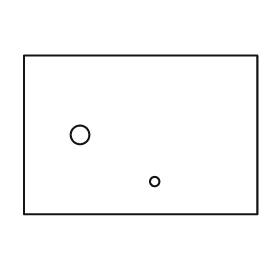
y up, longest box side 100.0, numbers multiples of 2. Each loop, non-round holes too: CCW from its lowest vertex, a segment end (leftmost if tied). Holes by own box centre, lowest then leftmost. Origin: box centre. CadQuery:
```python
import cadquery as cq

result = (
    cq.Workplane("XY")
    .moveTo(-50.0, -34.0)
    .lineTo(50.0, -34.0)
    .lineTo(50.0, 34.0)
    .lineTo(-50.0, 34.0)
    .close()
    .moveTo(6.0, -20.0)
    .circle(2.0)
    .moveTo(-26.0, 0.0)
    .circle(4.0)
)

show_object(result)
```